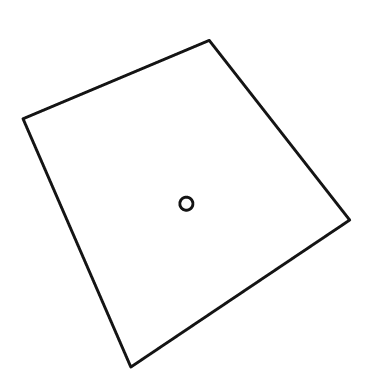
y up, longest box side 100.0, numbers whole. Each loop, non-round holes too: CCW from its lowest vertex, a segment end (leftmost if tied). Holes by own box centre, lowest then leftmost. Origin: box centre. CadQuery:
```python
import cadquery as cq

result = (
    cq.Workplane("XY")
    .moveTo(-17.0, -50.0)
    .lineTo(50.0, -5.0)
    .lineTo(7.0, 50.0)
    .lineTo(-50.0, 26.0)
    .close()
    .moveTo(0.0, 0.0)
    .circle(2.0)
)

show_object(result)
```